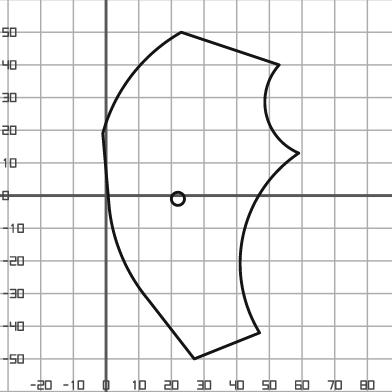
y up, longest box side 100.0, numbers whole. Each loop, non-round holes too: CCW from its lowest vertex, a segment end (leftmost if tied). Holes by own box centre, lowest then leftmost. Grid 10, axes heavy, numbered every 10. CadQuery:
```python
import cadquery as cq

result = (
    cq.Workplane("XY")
    .moveTo(27.0, -50.0)
    .lineTo(47.0, -42.0)
    .threePointArc((42.0, -12.0), (59.0, 13.0))
    .threePointArc((49.0, 25.0), (53.0, 40.0))
    .lineTo(23.0, 50.0)
    .threePointArc((8.0, 37.0), (-1.0, 19.0))
    .lineTo(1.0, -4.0)
    .threePointArc((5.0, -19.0), (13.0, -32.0))
    .close()
    .moveTo(22.0, -1.0)
    .circle(2.0)
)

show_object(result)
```